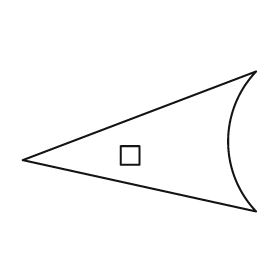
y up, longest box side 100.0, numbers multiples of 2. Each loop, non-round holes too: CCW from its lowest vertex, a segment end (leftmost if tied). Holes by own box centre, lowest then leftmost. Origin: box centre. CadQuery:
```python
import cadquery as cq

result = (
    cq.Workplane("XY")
    .moveTo(50.0, -30.0)
    .threePointArc((38.0, 0.0), (50.0, 30.0))
    .lineTo(-50.0, -8.0)
    .close()
    .moveTo(-8.0, -10.0)
    .lineTo(0.0, -10.0)
    .lineTo(0.0, -2.0)
    .lineTo(-8.0, -2.0)
    .close()
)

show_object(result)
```